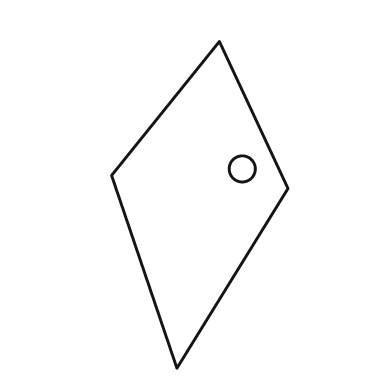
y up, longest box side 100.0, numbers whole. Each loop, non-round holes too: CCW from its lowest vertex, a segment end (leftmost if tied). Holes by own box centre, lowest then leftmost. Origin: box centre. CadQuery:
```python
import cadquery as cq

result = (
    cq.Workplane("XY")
    .moveTo(-7.0, -50.0)
    .lineTo(27.0, 5.0)
    .lineTo(6.0, 50.0)
    .lineTo(-27.0, 9.0)
    .close()
    .moveTo(13.0, 11.0)
    .circle(4.0)
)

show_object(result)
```